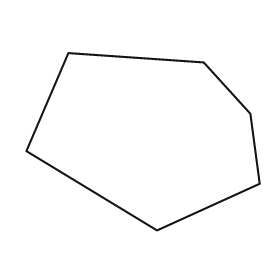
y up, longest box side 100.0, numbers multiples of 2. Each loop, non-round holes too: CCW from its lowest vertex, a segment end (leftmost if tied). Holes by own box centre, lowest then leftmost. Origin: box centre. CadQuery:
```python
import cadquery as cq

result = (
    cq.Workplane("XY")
    .moveTo(6.0, -38.0)
    .lineTo(50.0, -18.0)
    .lineTo(46.0, 12.0)
    .lineTo(26.0, 34.0)
    .lineTo(-32.0, 38.0)
    .lineTo(-50.0, -4.0)
    .close()
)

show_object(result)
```